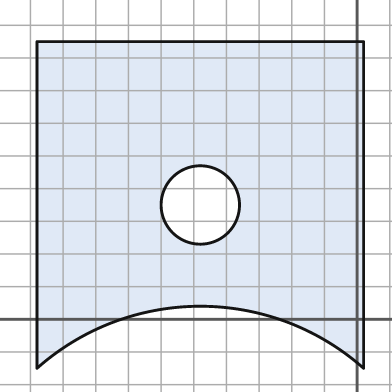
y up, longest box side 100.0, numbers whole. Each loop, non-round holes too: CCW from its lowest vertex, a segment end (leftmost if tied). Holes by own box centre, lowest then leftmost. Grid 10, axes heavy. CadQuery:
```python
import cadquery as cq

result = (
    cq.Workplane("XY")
    .moveTo(-98.0, -15.0)
    .threePointArc((-48.0, 4.0), (2.0, -15.0))
    .lineTo(2.0, 85.0)
    .lineTo(-98.0, 85.0)
    .close()
    .moveTo(-48.0, 35.0)
    .circle(12.0)
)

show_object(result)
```